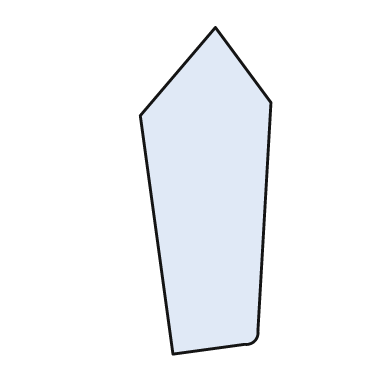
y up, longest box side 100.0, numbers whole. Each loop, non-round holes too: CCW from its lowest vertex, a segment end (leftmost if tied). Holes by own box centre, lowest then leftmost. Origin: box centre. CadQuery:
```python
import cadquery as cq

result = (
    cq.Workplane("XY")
    .moveTo(-10.0, -50.0)
    .lineTo(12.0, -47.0)
    .threePointArc((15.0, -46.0), (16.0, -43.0))
    .lineTo(20.0, 27.0)
    .lineTo(3.0, 50.0)
    .lineTo(-20.0, 23.0)
    .close()
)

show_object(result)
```